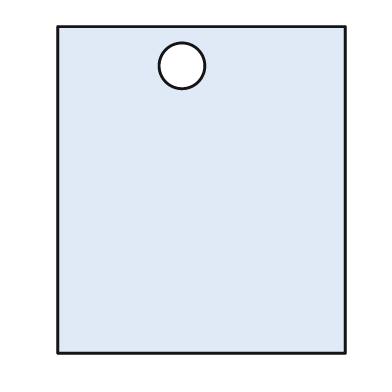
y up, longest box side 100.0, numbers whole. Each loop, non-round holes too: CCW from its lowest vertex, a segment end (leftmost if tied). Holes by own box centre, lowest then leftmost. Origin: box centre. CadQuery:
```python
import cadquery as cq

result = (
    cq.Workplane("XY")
    .moveTo(-44.0, -50.0)
    .lineTo(44.0, -50.0)
    .lineTo(44.0, 50.0)
    .lineTo(-44.0, 50.0)
    .close()
    .moveTo(-6.0, 38.0)
    .circle(7.0)
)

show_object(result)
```